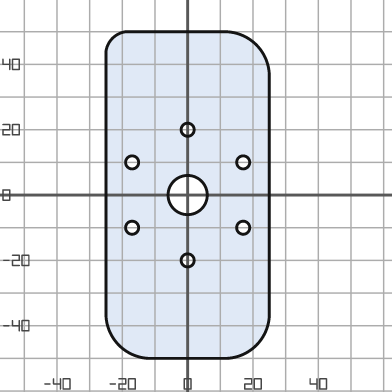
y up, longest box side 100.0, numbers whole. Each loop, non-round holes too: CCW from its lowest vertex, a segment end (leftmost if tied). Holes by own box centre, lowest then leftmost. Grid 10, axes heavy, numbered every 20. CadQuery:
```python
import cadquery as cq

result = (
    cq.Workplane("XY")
    .moveTo(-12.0, -50.0)
    .lineTo(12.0, -50.0)
    .threePointArc((21.0, -46.0), (25.0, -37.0))
    .lineTo(25.0, 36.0)
    .threePointArc((21.0, 46.0), (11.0, 50.0))
    .lineTo(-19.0, 50.0)
    .threePointArc((-23.0, 48.0), (-25.0, 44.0))
    .lineTo(-25.0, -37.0)
    .threePointArc((-21.0, -46.0), (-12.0, -50.0))
    .close()
    .moveTo(0.0, -20.0)
    .circle(2.0)
    .moveTo(-17.0, -10.0)
    .circle(2.0)
    .moveTo(17.0, -10.0)
    .circle(2.0)
    .moveTo(0.0, 0.0)
    .circle(6.0)
    .moveTo(-17.0, 10.0)
    .circle(2.0)
    .moveTo(17.0, 10.0)
    .circle(2.0)
    .moveTo(0.0, 20.0)
    .circle(2.0)
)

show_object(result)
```